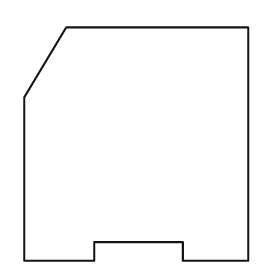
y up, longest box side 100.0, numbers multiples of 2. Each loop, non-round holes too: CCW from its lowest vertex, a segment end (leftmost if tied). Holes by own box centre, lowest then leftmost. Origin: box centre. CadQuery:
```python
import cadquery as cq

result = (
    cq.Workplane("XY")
    .moveTo(-48.0, -50.0)
    .lineTo(-18.0, -50.0)
    .lineTo(-18.0, -42.0)
    .lineTo(20.0, -42.0)
    .lineTo(20.0, -50.0)
    .lineTo(48.0, -50.0)
    .lineTo(48.0, 50.0)
    .lineTo(-30.0, 50.0)
    .lineTo(-48.0, 20.0)
    .close()
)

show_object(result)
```